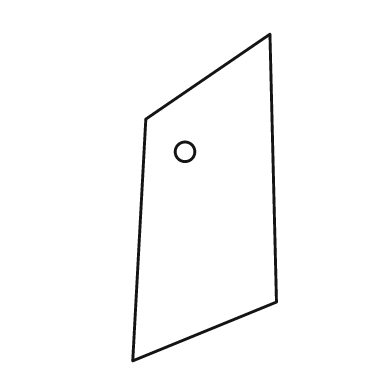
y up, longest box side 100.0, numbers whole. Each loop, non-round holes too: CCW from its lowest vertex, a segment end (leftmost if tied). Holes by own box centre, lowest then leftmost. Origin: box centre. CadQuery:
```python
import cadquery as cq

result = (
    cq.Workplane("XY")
    .moveTo(-22.0, -50.0)
    .lineTo(22.0, -32.0)
    .lineTo(20.0, 50.0)
    .lineTo(-18.0, 24.0)
    .close()
    .moveTo(-6.0, 14.0)
    .circle(3.0)
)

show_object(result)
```